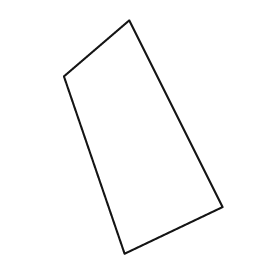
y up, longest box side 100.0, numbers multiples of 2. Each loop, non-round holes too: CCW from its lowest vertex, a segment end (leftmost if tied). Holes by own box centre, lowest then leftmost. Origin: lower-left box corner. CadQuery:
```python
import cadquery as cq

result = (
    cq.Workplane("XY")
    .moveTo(26.0, 0.0)
    .lineTo(68.0, 20.0)
    .lineTo(28.0, 100.0)
    .lineTo(0.0, 76.0)
    .close()
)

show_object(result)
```